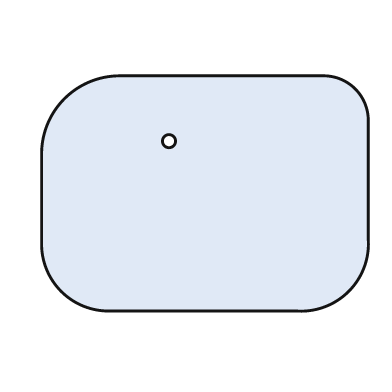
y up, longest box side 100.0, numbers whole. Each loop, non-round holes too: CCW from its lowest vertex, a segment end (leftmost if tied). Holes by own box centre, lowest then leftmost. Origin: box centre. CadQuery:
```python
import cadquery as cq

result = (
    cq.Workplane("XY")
    .moveTo(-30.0, -36.0)
    .lineTo(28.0, -36.0)
    .threePointArc((44.0, -30.0), (50.0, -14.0))
    .lineTo(50.0, 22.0)
    .threePointArc((46.0, 32.0), (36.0, 36.0))
    .lineTo(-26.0, 36.0)
    .threePointArc((-43.0, 29.0), (-50.0, 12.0))
    .lineTo(-50.0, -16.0)
    .threePointArc((-44.0, -30.0), (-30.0, -36.0))
    .close()
    .moveTo(-11.0, 16.0)
    .circle(2.0)
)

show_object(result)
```